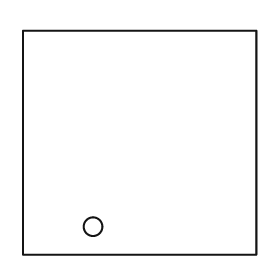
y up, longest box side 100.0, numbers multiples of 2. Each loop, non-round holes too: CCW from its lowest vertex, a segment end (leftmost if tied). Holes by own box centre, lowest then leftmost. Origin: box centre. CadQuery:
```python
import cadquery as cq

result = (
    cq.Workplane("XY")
    .moveTo(-50.0, -48.0)
    .lineTo(50.0, -48.0)
    .lineTo(50.0, 48.0)
    .lineTo(-50.0, 48.0)
    .close()
    .moveTo(-20.0, -36.0)
    .circle(4.0)
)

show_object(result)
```